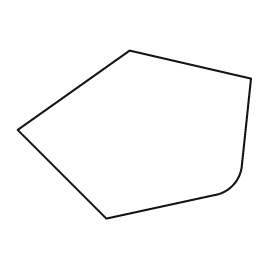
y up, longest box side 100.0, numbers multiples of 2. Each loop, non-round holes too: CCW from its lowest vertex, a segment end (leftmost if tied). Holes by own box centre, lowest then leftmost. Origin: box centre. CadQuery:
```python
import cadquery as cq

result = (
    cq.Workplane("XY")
    .moveTo(-12.0, -36.0)
    .lineTo(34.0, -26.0)
    .threePointArc((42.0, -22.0), (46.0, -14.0))
    .lineTo(50.0, 24.0)
    .lineTo(-2.0, 36.0)
    .lineTo(-50.0, 2.0)
    .close()
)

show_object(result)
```